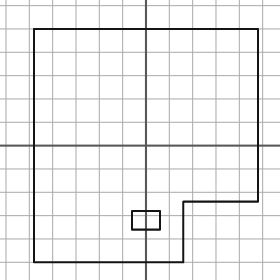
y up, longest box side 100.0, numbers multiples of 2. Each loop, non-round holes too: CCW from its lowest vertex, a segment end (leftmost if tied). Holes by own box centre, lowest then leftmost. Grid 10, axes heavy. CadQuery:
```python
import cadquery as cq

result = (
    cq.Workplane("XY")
    .moveTo(-48.0, -50.0)
    .lineTo(16.0, -50.0)
    .lineTo(16.0, -24.0)
    .lineTo(48.0, -24.0)
    .lineTo(48.0, 50.0)
    .lineTo(-48.0, 50.0)
    .close()
    .moveTo(-6.0, -36.0)
    .lineTo(6.0, -36.0)
    .lineTo(6.0, -28.0)
    .lineTo(-6.0, -28.0)
    .close()
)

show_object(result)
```